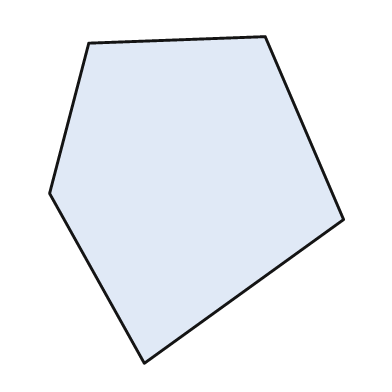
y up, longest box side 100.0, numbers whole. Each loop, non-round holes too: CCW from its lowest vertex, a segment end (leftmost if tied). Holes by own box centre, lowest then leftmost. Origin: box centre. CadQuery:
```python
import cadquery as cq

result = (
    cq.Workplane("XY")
    .moveTo(-16.0, -50.0)
    .lineTo(45.0, -6.0)
    .lineTo(21.0, 50.0)
    .lineTo(-33.0, 48.0)
    .lineTo(-45.0, 2.0)
    .close()
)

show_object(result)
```